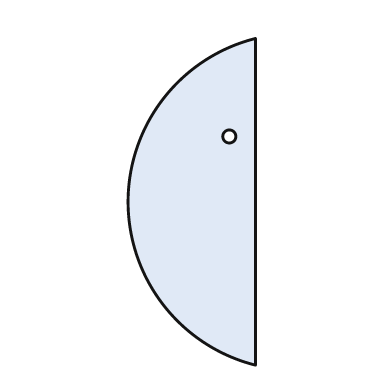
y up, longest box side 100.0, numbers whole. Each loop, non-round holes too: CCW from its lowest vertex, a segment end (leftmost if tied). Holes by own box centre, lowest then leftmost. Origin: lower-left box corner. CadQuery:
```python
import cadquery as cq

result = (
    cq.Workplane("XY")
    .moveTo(39.0, 0.0)
    .lineTo(39.0, 100.0)
    .threePointArc((0.0, 50.0), (39.0, 0.0))
    .close()
    .moveTo(31.0, 70.0)
    .circle(2.0)
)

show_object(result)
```